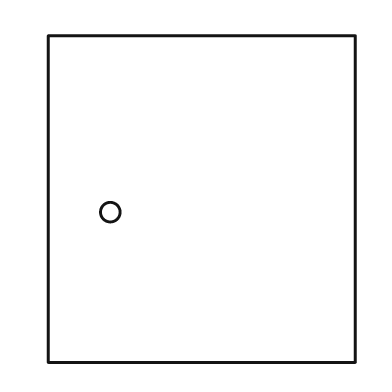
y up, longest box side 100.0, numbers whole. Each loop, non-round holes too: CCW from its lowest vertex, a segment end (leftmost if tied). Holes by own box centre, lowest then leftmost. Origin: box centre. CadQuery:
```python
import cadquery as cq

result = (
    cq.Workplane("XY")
    .moveTo(-47.0, -50.0)
    .lineTo(47.0, -50.0)
    .lineTo(47.0, 50.0)
    .lineTo(-47.0, 50.0)
    .close()
    .moveTo(-28.0, -4.0)
    .circle(3.0)
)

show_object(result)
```